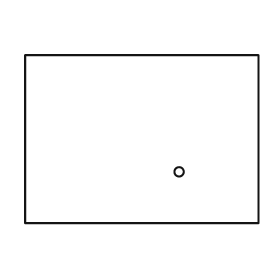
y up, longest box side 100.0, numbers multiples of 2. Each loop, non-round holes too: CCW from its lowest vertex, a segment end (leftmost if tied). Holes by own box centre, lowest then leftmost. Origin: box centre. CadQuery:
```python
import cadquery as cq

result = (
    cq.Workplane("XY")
    .moveTo(-50.0, -36.0)
    .lineTo(50.0, -36.0)
    .lineTo(50.0, 36.0)
    .lineTo(-50.0, 36.0)
    .close()
    .moveTo(16.0, -14.0)
    .circle(2.0)
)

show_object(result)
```